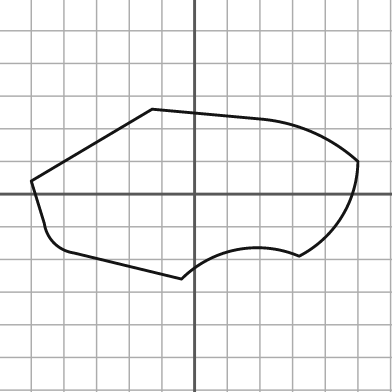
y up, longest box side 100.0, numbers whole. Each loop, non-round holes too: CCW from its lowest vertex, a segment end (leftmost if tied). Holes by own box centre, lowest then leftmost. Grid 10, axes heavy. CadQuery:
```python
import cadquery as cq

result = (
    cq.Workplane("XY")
    .moveTo(-4.0, -26.0)
    .threePointArc((13.0, -17.0), (32.0, -19.0))
    .threePointArc((45.0, -7.0), (50.0, 10.0))
    .threePointArc((36.0, 19.0), (20.0, 23.0))
    .lineTo(-13.0, 26.0)
    .lineTo(-50.0, 4.0)
    .lineTo(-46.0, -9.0)
    .threePointArc((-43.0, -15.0), (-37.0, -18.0))
    .close()
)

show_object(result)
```